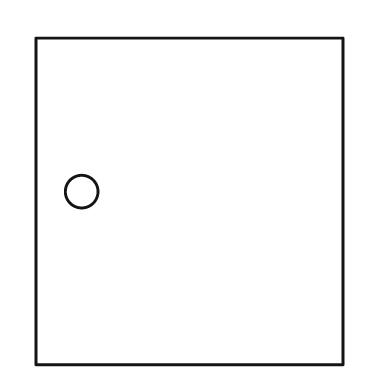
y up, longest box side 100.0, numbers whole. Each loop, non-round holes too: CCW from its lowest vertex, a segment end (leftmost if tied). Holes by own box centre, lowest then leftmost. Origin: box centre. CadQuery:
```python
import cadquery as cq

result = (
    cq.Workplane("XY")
    .moveTo(-47.0, -50.0)
    .lineTo(47.0, -50.0)
    .lineTo(47.0, 50.0)
    .lineTo(-47.0, 50.0)
    .close()
    .moveTo(-33.0, 3.0)
    .circle(5.0)
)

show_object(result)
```